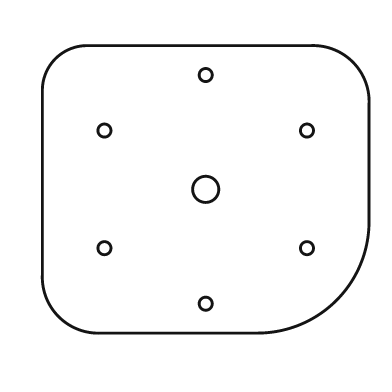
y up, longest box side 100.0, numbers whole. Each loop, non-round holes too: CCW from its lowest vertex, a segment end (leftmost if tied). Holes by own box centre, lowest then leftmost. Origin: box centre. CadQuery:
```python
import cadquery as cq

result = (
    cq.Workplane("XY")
    .moveTo(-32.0, -44.0)
    .lineTo(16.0, -44.0)
    .threePointArc((40.0, -34.0), (50.0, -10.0))
    .lineTo(50.0, 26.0)
    .threePointArc((45.0, 39.0), (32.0, 44.0))
    .lineTo(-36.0, 44.0)
    .threePointArc((-46.0, 40.0), (-50.0, 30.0))
    .lineTo(-50.0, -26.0)
    .threePointArc((-45.0, -39.0), (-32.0, -44.0))
    .close()
    .moveTo(0.0, -35.0)
    .circle(2.0)
    .moveTo(-31.0, -18.0)
    .circle(2.0)
    .moveTo(31.0, -18.0)
    .circle(2.0)
    .moveTo(0.0, 0.0)
    .circle(4.0)
    .moveTo(-31.0, 18.0)
    .circle(2.0)
    .moveTo(31.0, 18.0)
    .circle(2.0)
    .moveTo(0.0, 35.0)
    .circle(2.0)
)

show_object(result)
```